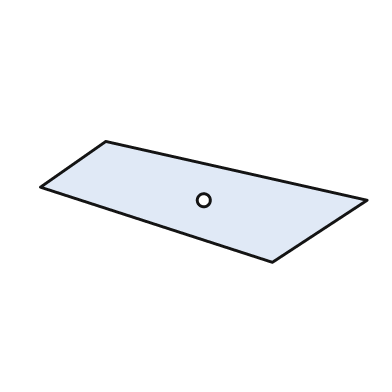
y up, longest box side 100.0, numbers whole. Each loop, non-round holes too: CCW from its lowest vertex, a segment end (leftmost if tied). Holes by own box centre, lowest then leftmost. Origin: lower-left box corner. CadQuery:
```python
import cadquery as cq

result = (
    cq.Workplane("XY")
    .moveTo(71.0, 0.0)
    .lineTo(100.0, 19.0)
    .lineTo(20.0, 37.0)
    .lineTo(0.0, 23.0)
    .close()
    .moveTo(50.0, 19.0)
    .circle(2.0)
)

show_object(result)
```